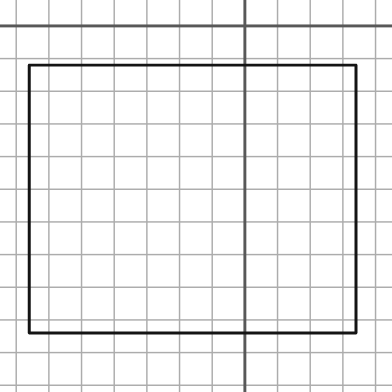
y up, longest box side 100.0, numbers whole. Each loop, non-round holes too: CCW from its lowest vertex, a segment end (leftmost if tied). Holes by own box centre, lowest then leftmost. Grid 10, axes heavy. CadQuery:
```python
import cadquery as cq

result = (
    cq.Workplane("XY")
    .moveTo(-66.0, -94.0)
    .lineTo(34.0, -94.0)
    .lineTo(34.0, -12.0)
    .lineTo(-66.0, -12.0)
    .close()
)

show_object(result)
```